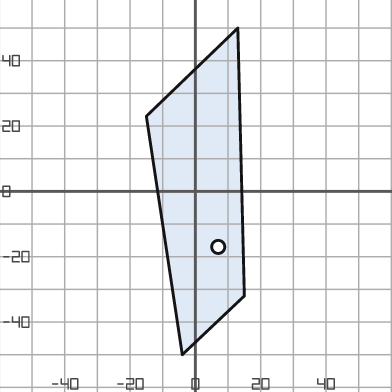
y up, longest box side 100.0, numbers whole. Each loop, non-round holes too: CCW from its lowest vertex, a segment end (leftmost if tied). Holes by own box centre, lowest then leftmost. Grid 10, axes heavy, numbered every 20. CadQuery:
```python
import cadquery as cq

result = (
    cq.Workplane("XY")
    .moveTo(-4.0, -50.0)
    .lineTo(15.0, -32.0)
    .lineTo(13.0, 50.0)
    .lineTo(-15.0, 23.0)
    .close()
    .moveTo(7.0, -17.0)
    .circle(2.0)
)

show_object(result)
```